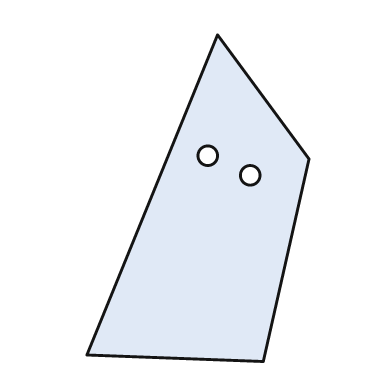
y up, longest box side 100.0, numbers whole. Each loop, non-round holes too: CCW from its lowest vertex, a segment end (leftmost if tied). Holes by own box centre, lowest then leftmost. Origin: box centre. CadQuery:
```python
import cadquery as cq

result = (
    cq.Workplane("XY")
    .moveTo(20.0, -50.0)
    .lineTo(34.0, 12.0)
    .lineTo(6.0, 50.0)
    .lineTo(-34.0, -48.0)
    .close()
    .moveTo(16.0, 7.0)
    .circle(3.0)
    .moveTo(3.0, 13.0)
    .circle(3.0)
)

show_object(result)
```